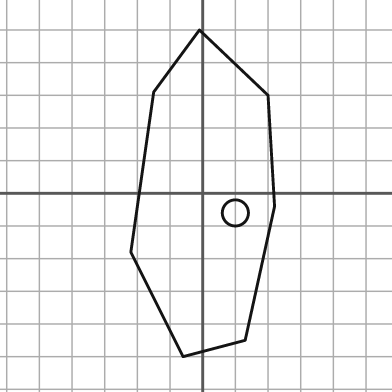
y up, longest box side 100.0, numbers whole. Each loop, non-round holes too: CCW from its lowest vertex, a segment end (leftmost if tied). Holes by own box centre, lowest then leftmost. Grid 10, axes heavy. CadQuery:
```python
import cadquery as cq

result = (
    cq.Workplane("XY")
    .moveTo(-6.0, -50.0)
    .lineTo(13.0, -45.0)
    .lineTo(22.0, -4.0)
    .lineTo(20.0, 30.0)
    .lineTo(-1.0, 50.0)
    .lineTo(-15.0, 31.0)
    .lineTo(-22.0, -18.0)
    .close()
    .moveTo(10.0, -6.0)
    .circle(4.0)
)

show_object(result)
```